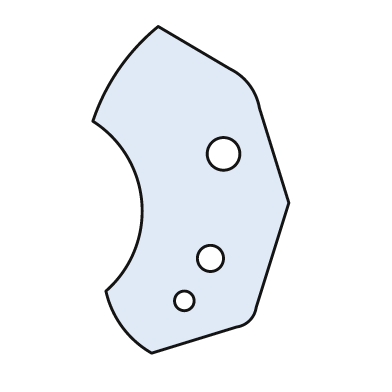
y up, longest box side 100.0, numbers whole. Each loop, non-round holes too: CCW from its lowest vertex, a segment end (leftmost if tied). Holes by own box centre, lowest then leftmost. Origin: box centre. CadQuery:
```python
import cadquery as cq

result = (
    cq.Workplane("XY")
    .moveTo(-12.0, -50.0)
    .lineTo(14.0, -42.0)
    .threePointArc((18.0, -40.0), (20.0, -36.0))
    .lineTo(30.0, -4.0)
    .lineTo(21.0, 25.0)
    .threePointArc((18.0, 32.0), (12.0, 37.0))
    .lineTo(-10.0, 50.0)
    .threePointArc((-22.0, 37.0), (-30.0, 21.0))
    .threePointArc((-15.0, -4.0), (-26.0, -31.0))
    .threePointArc((-21.0, -42.0), (-12.0, -50.0))
    .close()
    .moveTo(-2.0, -34.0)
    .circle(3.0)
    .moveTo(6.0, -21.0)
    .circle(4.0)
    .moveTo(10.0, 11.0)
    .circle(5.0)
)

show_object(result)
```